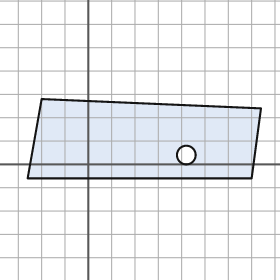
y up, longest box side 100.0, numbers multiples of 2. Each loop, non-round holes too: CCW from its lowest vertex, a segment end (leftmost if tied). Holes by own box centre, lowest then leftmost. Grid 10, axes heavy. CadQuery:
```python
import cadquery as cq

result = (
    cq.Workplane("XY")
    .moveTo(-26.0, -6.0)
    .lineTo(70.0, -6.0)
    .lineTo(74.0, 24.0)
    .lineTo(-20.0, 28.0)
    .close()
    .moveTo(42.0, 4.0)
    .circle(4.0)
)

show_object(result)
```